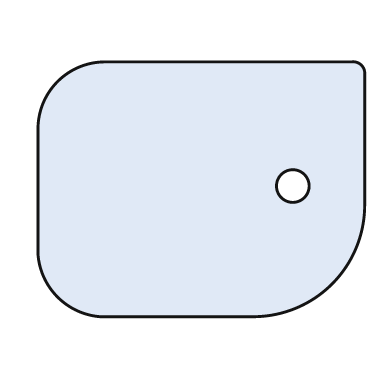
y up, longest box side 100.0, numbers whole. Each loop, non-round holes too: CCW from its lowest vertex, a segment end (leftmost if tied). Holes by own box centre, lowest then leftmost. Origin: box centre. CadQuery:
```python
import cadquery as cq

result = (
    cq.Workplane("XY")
    .moveTo(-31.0, -39.0)
    .lineTo(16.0, -39.0)
    .threePointArc((40.0, -29.0), (50.0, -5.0))
    .lineTo(50.0, 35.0)
    .threePointArc((49.0, 38.0), (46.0, 39.0))
    .lineTo(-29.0, 39.0)
    .threePointArc((-44.0, 33.0), (-50.0, 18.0))
    .lineTo(-50.0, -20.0)
    .threePointArc((-44.0, -33.0), (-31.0, -39.0))
    .close()
    .moveTo(28.0, 1.0)
    .circle(5.0)
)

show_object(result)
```